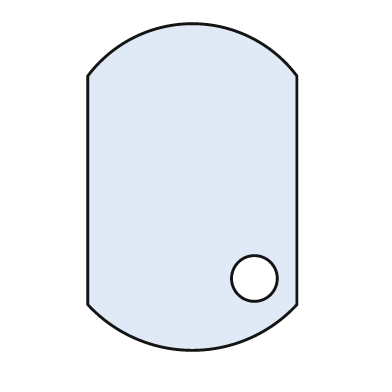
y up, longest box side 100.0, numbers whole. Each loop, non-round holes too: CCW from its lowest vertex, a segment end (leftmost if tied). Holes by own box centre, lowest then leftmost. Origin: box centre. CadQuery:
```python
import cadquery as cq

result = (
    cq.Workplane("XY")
    .moveTo(-32.0, -36.0)
    .threePointArc((0.0, -50.0), (32.0, -36.0))
    .lineTo(32.0, 34.0)
    .threePointArc((0.0, 50.0), (-32.0, 34.0))
    .close()
    .moveTo(19.0, -28.0)
    .circle(7.0)
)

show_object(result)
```